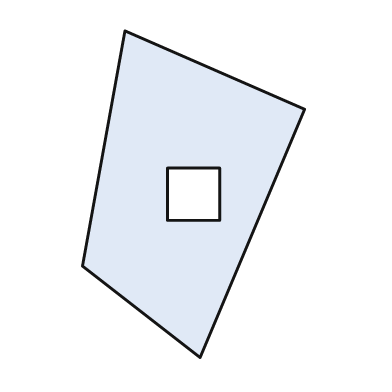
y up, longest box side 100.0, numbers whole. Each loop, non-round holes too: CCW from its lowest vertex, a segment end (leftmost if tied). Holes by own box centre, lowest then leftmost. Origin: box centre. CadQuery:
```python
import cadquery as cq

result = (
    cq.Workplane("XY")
    .moveTo(2.0, -50.0)
    .lineTo(34.0, 26.0)
    .lineTo(-21.0, 50.0)
    .lineTo(-34.0, -22.0)
    .close()
    .moveTo(-8.0, -8.0)
    .lineTo(8.0, -8.0)
    .lineTo(8.0, 8.0)
    .lineTo(-8.0, 8.0)
    .close()
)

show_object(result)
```